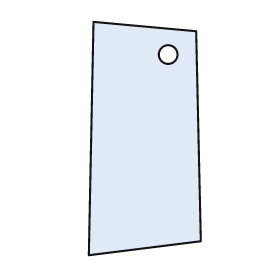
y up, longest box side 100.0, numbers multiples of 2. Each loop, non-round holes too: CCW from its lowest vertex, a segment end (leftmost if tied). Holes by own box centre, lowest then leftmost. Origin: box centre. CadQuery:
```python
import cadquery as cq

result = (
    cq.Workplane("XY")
    .moveTo(-24.0, -50.0)
    .lineTo(24.0, -44.0)
    .lineTo(22.0, 46.0)
    .lineTo(-22.0, 50.0)
    .close()
    .moveTo(10.0, 36.0)
    .circle(4.0)
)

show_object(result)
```